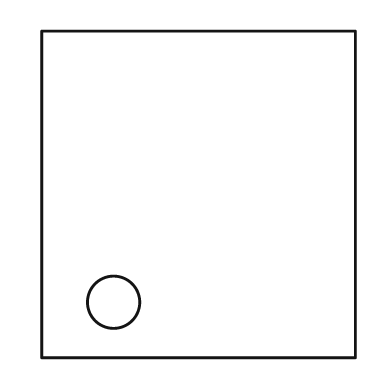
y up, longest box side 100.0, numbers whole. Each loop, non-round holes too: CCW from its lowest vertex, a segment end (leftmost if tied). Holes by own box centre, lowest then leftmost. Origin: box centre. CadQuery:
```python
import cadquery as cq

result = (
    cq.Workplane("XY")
    .moveTo(-48.0, -50.0)
    .lineTo(48.0, -50.0)
    .lineTo(48.0, 50.0)
    .lineTo(-48.0, 50.0)
    .close()
    .moveTo(-26.0, -33.0)
    .circle(8.0)
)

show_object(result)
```